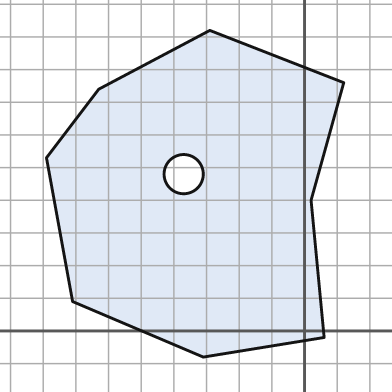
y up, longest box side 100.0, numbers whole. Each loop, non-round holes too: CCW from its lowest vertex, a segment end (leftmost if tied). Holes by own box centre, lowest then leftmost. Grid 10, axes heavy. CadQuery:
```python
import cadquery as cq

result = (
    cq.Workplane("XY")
    .moveTo(-31.0, -8.0)
    .lineTo(6.0, -2.0)
    .lineTo(2.0, 40.0)
    .lineTo(12.0, 76.0)
    .lineTo(-29.0, 92.0)
    .lineTo(-63.0, 74.0)
    .lineTo(-79.0, 53.0)
    .lineTo(-71.0, 9.0)
    .close()
    .moveTo(-37.0, 48.0)
    .circle(6.0)
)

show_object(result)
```